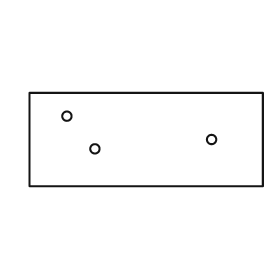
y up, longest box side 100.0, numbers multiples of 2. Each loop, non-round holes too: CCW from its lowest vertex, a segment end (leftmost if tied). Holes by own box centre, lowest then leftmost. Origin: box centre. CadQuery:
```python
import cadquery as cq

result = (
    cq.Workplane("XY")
    .moveTo(-50.0, -20.0)
    .lineTo(50.0, -20.0)
    .lineTo(50.0, 20.0)
    .lineTo(-50.0, 20.0)
    .close()
    .moveTo(-22.0, -4.0)
    .circle(2.0)
    .moveTo(28.0, 0.0)
    .circle(2.0)
    .moveTo(-34.0, 10.0)
    .circle(2.0)
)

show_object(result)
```